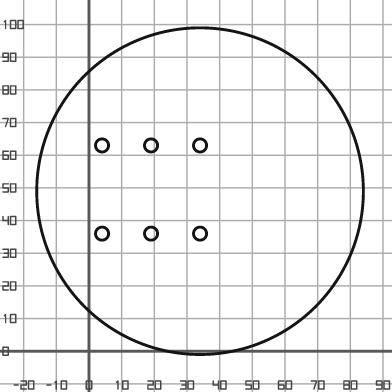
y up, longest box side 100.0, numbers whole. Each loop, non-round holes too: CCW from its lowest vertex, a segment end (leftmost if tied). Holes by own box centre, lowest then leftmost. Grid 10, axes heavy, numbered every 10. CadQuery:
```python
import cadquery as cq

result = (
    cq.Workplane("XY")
    .moveTo(34.0, 49.0)
    .circle(50.0)
    .moveTo(4.0, 36.0)
    .circle(2.0)
    .moveTo(19.0, 36.0)
    .circle(2.0)
    .moveTo(34.0, 36.0)
    .circle(2.0)
    .moveTo(4.0, 63.0)
    .circle(2.0)
    .moveTo(19.0, 63.0)
    .circle(2.0)
    .moveTo(34.0, 63.0)
    .circle(2.0)
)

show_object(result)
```